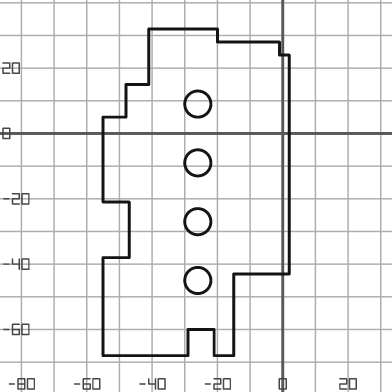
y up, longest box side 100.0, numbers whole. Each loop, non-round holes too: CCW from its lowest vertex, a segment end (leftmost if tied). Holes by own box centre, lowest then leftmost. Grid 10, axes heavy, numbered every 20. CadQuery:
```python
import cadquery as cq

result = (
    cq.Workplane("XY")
    .moveTo(-55.0, -68.0)
    .lineTo(-29.0, -68.0)
    .lineTo(-29.0, -60.0)
    .lineTo(-21.0, -60.0)
    .lineTo(-21.0, -68.0)
    .lineTo(-15.0, -68.0)
    .lineTo(-15.0, -43.0)
    .lineTo(2.0, -43.0)
    .lineTo(2.0, 24.0)
    .lineTo(-1.0, 24.0)
    .lineTo(-1.0, 28.0)
    .lineTo(-20.0, 28.0)
    .lineTo(-20.0, 32.0)
    .lineTo(-41.0, 32.0)
    .lineTo(-41.0, 15.0)
    .lineTo(-48.0, 15.0)
    .lineTo(-48.0, 5.0)
    .lineTo(-55.0, 5.0)
    .lineTo(-55.0, -21.0)
    .lineTo(-47.0, -21.0)
    .lineTo(-47.0, -38.0)
    .lineTo(-55.0, -38.0)
    .close()
    .moveTo(-26.0, -45.0)
    .circle(4.0)
    .moveTo(-26.0, -27.0)
    .circle(4.0)
    .moveTo(-26.0, -9.0)
    .circle(4.0)
    .moveTo(-26.0, 9.0)
    .circle(4.0)
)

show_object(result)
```